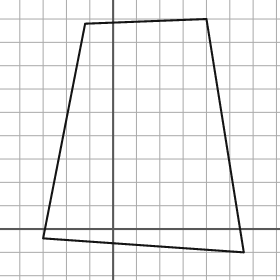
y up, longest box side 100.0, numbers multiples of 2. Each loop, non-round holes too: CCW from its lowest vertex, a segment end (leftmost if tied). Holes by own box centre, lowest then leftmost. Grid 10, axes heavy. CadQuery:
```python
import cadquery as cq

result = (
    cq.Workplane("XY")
    .moveTo(56.0, -10.0)
    .lineTo(40.0, 90.0)
    .lineTo(-12.0, 88.0)
    .lineTo(-30.0, -4.0)
    .close()
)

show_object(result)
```